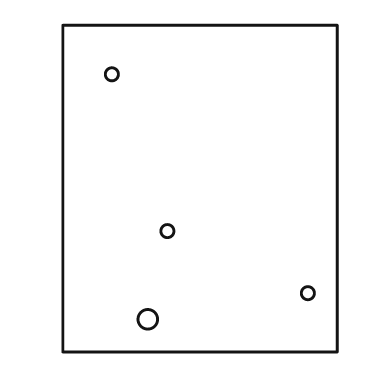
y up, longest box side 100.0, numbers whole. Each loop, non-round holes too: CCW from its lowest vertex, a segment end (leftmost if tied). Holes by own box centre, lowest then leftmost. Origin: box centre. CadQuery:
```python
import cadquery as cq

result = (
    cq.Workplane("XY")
    .moveTo(-42.0, -50.0)
    .lineTo(42.0, -50.0)
    .lineTo(42.0, 50.0)
    .lineTo(-42.0, 50.0)
    .close()
    .moveTo(-16.0, -40.0)
    .circle(3.0)
    .moveTo(33.0, -32.0)
    .circle(2.0)
    .moveTo(-10.0, -13.0)
    .circle(2.0)
    .moveTo(-27.0, 35.0)
    .circle(2.0)
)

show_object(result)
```